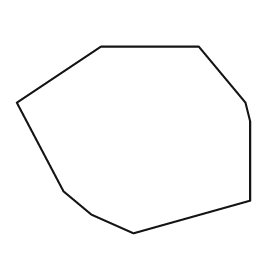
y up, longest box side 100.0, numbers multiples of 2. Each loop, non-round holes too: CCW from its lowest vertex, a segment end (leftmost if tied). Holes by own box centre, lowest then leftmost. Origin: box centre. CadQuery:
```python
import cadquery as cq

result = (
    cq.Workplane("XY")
    .moveTo(0.0, -40.0)
    .lineTo(50.0, -26.0)
    .lineTo(50.0, 8.0)
    .lineTo(48.0, 16.0)
    .lineTo(28.0, 40.0)
    .lineTo(-14.0, 40.0)
    .lineTo(-50.0, 16.0)
    .lineTo(-30.0, -22.0)
    .lineTo(-18.0, -32.0)
    .close()
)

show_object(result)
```